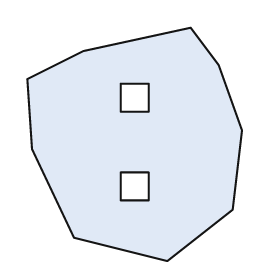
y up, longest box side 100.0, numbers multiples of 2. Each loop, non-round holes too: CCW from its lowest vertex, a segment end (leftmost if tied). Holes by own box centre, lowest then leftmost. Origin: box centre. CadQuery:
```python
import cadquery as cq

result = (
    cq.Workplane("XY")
    .moveTo(14.0, -50.0)
    .lineTo(42.0, -28.0)
    .lineTo(46.0, 6.0)
    .lineTo(36.0, 34.0)
    .lineTo(24.0, 50.0)
    .lineTo(-22.0, 40.0)
    .lineTo(-46.0, 28.0)
    .lineTo(-44.0, -2.0)
    .lineTo(-26.0, -40.0)
    .close()
    .moveTo(-6.0, -24.0)
    .lineTo(6.0, -24.0)
    .lineTo(6.0, -12.0)
    .lineTo(-6.0, -12.0)
    .close()
    .moveTo(-6.0, 14.0)
    .lineTo(6.0, 14.0)
    .lineTo(6.0, 26.0)
    .lineTo(-6.0, 26.0)
    .close()
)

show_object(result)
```